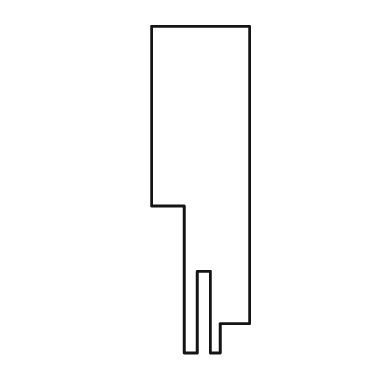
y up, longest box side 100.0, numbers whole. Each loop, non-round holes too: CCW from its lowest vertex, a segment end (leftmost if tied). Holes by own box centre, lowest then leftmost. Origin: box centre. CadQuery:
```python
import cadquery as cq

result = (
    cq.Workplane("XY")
    .moveTo(-5.0, -50.0)
    .lineTo(-1.0, -50.0)
    .lineTo(-1.0, -25.0)
    .lineTo(3.0, -25.0)
    .lineTo(3.0, -50.0)
    .lineTo(6.0, -50.0)
    .lineTo(6.0, -41.0)
    .lineTo(15.0, -41.0)
    .lineTo(15.0, 50.0)
    .lineTo(-15.0, 50.0)
    .lineTo(-15.0, -5.0)
    .lineTo(-5.0, -5.0)
    .close()
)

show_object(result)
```